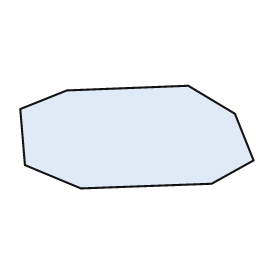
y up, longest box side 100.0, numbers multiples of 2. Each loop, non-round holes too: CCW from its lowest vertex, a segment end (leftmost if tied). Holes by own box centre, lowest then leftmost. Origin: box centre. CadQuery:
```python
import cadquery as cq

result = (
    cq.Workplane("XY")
    .moveTo(-24.0, -22.0)
    .lineTo(32.0, -20.0)
    .lineTo(50.0, -10.0)
    .lineTo(42.0, 10.0)
    .lineTo(22.0, 22.0)
    .lineTo(-30.0, 20.0)
    .lineTo(-50.0, 12.0)
    .lineTo(-48.0, -12.0)
    .close()
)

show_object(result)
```